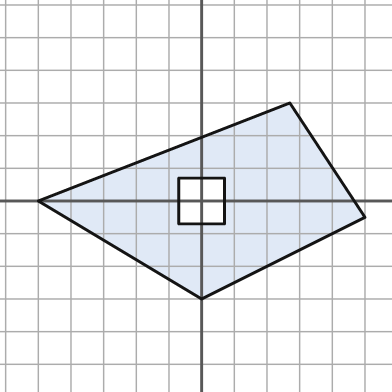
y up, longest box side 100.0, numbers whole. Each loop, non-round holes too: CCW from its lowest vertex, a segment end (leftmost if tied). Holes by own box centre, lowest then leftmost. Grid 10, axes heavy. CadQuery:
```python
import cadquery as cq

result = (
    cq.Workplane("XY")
    .moveTo(0.0, -30.0)
    .lineTo(50.0, -5.0)
    .lineTo(27.0, 30.0)
    .lineTo(-50.0, 0.0)
    .close()
    .moveTo(-7.0, -7.0)
    .lineTo(7.0, -7.0)
    .lineTo(7.0, 7.0)
    .lineTo(-7.0, 7.0)
    .close()
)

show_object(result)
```